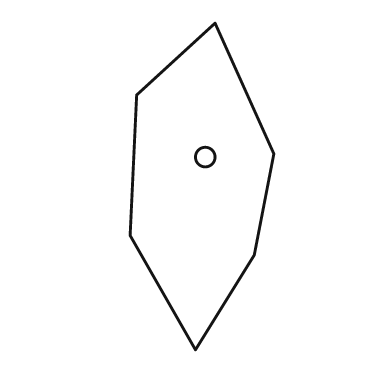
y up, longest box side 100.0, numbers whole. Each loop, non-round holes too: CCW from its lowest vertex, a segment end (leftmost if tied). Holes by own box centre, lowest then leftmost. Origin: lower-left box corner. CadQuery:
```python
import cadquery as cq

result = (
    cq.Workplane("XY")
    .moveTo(20.0, 0.0)
    .lineTo(38.0, 29.0)
    .lineTo(44.0, 60.0)
    .lineTo(26.0, 100.0)
    .lineTo(2.0, 78.0)
    .lineTo(0.0, 35.0)
    .close()
    .moveTo(23.0, 59.0)
    .circle(3.0)
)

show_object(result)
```